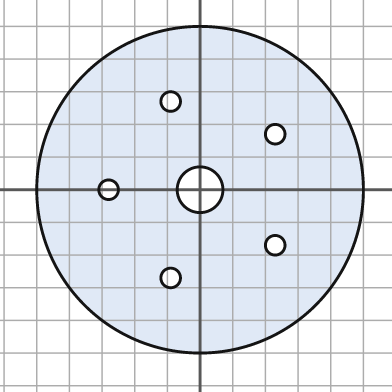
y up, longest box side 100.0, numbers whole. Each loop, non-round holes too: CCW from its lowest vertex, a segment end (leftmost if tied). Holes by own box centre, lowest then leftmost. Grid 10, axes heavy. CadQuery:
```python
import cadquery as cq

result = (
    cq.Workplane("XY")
    .moveTo(0.0, 0.0)
    .circle(50.0)
    .moveTo(-9.0, -27.0)
    .circle(3.0)
    .moveTo(23.0, -17.0)
    .circle(3.0)
    .moveTo(-28.0, 0.0)
    .circle(3.0)
    .moveTo(0.0, 0.0)
    .circle(7.0)
    .moveTo(23.0, 17.0)
    .circle(3.0)
    .moveTo(-9.0, 27.0)
    .circle(3.0)
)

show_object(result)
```